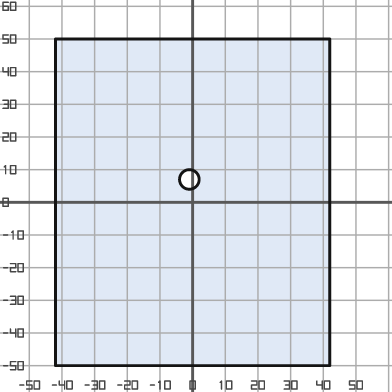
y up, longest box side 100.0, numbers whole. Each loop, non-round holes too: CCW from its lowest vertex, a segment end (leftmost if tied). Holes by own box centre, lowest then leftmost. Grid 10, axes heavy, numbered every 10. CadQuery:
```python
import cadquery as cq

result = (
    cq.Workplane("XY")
    .moveTo(-42.0, -50.0)
    .lineTo(42.0, -50.0)
    .lineTo(42.0, 50.0)
    .lineTo(-42.0, 50.0)
    .close()
    .moveTo(-1.0, 7.0)
    .circle(3.0)
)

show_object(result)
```